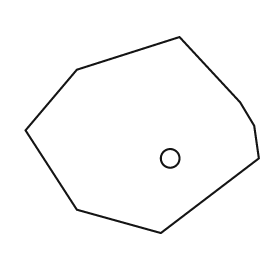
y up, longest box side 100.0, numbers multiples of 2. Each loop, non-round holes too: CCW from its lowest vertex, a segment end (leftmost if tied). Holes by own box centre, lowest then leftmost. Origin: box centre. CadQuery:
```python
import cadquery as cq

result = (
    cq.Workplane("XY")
    .moveTo(8.0, -42.0)
    .lineTo(50.0, -10.0)
    .lineTo(48.0, 4.0)
    .lineTo(42.0, 14.0)
    .lineTo(16.0, 42.0)
    .lineTo(-28.0, 28.0)
    .lineTo(-50.0, 2.0)
    .lineTo(-28.0, -32.0)
    .close()
    .moveTo(12.0, -10.0)
    .circle(4.0)
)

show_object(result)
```